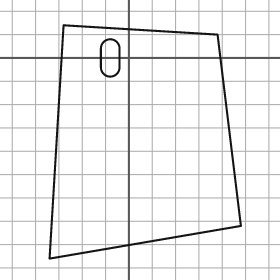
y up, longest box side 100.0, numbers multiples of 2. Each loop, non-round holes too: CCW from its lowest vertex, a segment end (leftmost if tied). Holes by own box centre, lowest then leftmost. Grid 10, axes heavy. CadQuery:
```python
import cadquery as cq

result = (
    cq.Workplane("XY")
    .moveTo(-34.0, -86.0)
    .lineTo(48.0, -72.0)
    .lineTo(38.0, 10.0)
    .lineTo(-28.0, 14.0)
    .close()
    .moveTo(-12.0, -4.0)
    .threePointArc((-8.0, -8.0), (-4.0, -4.0))
    .lineTo(-4.0, 4.0)
    .threePointArc((-8.0, 8.0), (-12.0, 4.0))
    .close()
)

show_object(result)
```